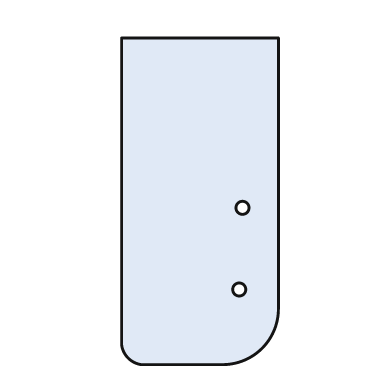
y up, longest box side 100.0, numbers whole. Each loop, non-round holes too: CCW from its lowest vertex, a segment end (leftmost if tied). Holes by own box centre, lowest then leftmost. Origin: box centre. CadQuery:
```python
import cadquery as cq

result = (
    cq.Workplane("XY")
    .moveTo(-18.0, -50.0)
    .lineTo(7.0, -50.0)
    .threePointArc((19.0, -45.0), (24.0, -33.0))
    .lineTo(24.0, 50.0)
    .lineTo(-24.0, 50.0)
    .lineTo(-24.0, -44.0)
    .threePointArc((-22.0, -48.0), (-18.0, -50.0))
    .close()
    .moveTo(12.0, -27.0)
    .circle(2.0)
    .moveTo(13.0, -2.0)
    .circle(2.0)
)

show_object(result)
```